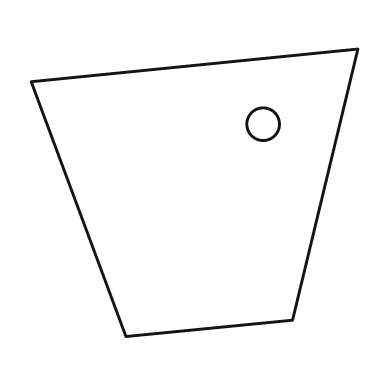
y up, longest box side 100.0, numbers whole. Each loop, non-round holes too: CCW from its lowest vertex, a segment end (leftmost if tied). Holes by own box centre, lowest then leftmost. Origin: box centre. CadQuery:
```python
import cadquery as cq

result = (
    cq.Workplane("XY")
    .moveTo(-21.0, -44.0)
    .lineTo(30.0, -39.0)
    .lineTo(50.0, 44.0)
    .lineTo(-50.0, 34.0)
    .close()
    .moveTo(21.0, 21.0)
    .circle(5.0)
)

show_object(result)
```